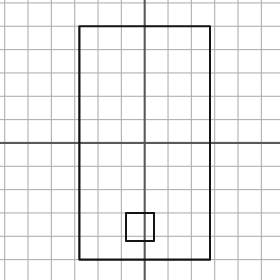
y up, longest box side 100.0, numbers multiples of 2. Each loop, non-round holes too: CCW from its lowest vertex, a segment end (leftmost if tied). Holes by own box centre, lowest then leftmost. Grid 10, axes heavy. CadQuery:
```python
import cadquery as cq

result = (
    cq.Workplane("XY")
    .moveTo(-28.0, -50.0)
    .lineTo(28.0, -50.0)
    .lineTo(28.0, 50.0)
    .lineTo(-28.0, 50.0)
    .close()
    .moveTo(-8.0, -42.0)
    .lineTo(4.0, -42.0)
    .lineTo(4.0, -30.0)
    .lineTo(-8.0, -30.0)
    .close()
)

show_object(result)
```